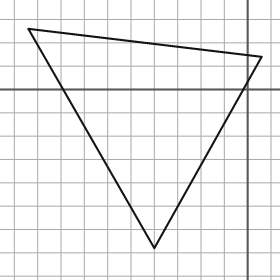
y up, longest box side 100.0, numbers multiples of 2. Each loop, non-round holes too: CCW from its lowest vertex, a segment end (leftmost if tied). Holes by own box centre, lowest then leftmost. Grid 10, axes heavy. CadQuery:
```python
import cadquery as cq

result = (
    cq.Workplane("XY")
    .moveTo(-40.0, -68.0)
    .lineTo(6.0, 14.0)
    .lineTo(-94.0, 26.0)
    .close()
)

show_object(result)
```